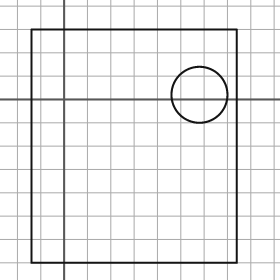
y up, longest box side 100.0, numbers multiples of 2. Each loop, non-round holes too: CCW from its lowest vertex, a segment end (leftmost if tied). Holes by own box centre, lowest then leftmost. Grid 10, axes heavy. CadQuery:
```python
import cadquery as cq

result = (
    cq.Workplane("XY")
    .moveTo(-14.0, -70.0)
    .lineTo(74.0, -70.0)
    .lineTo(74.0, 30.0)
    .lineTo(-14.0, 30.0)
    .close()
    .moveTo(58.0, 2.0)
    .circle(12.0)
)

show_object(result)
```